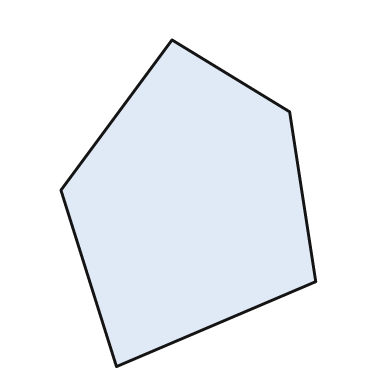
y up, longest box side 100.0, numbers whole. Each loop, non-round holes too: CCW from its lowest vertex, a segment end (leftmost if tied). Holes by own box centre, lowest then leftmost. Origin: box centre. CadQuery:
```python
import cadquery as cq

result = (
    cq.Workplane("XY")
    .moveTo(-22.0, -50.0)
    .lineTo(39.0, -24.0)
    .lineTo(31.0, 28.0)
    .lineTo(-5.0, 50.0)
    .lineTo(-39.0, 4.0)
    .close()
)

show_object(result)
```